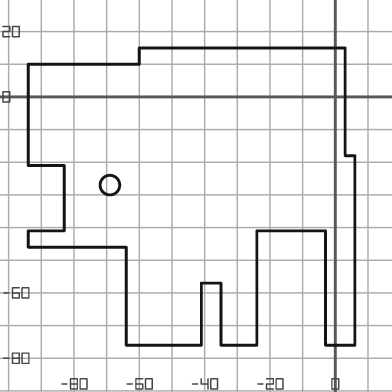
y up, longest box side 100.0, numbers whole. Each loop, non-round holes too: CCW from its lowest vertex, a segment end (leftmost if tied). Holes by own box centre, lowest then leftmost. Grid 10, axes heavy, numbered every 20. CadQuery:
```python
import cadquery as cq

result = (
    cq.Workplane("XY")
    .moveTo(-64.0, -76.0)
    .lineTo(-41.0, -76.0)
    .lineTo(-41.0, -57.0)
    .lineTo(-35.0, -57.0)
    .lineTo(-35.0, -76.0)
    .lineTo(-24.0, -76.0)
    .lineTo(-24.0, -41.0)
    .lineTo(-3.0, -41.0)
    .lineTo(-3.0, -76.0)
    .lineTo(6.0, -76.0)
    .lineTo(6.0, -18.0)
    .lineTo(3.0, -18.0)
    .lineTo(3.0, 15.0)
    .lineTo(-60.0, 15.0)
    .lineTo(-60.0, 10.0)
    .lineTo(-94.0, 10.0)
    .lineTo(-94.0, -21.0)
    .lineTo(-83.0, -21.0)
    .lineTo(-83.0, -41.0)
    .lineTo(-94.0, -41.0)
    .lineTo(-94.0, -46.0)
    .lineTo(-64.0, -46.0)
    .close()
    .moveTo(-69.0, -27.0)
    .circle(3.0)
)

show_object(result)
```